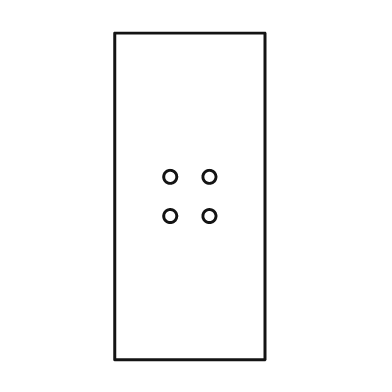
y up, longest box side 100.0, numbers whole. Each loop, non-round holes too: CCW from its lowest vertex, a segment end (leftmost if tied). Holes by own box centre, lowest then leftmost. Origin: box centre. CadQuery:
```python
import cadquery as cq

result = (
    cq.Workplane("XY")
    .moveTo(-23.0, -50.0)
    .lineTo(23.0, -50.0)
    .lineTo(23.0, 50.0)
    .lineTo(-23.0, 50.0)
    .close()
    .moveTo(-6.0, -6.0)
    .circle(2.0)
    .moveTo(6.0, -6.0)
    .circle(2.0)
    .moveTo(-6.0, 6.0)
    .circle(2.0)
    .moveTo(6.0, 6.0)
    .circle(2.0)
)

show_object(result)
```